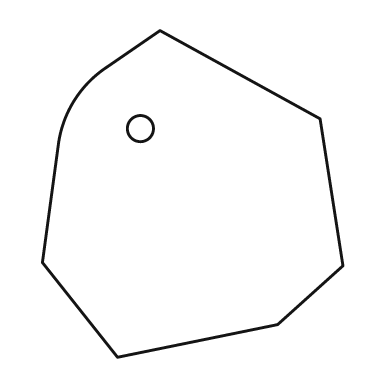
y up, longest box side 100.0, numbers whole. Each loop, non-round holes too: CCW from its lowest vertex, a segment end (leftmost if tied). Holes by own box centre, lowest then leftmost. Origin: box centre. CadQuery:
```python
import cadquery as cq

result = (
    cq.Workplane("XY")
    .moveTo(-23.0, -50.0)
    .lineTo(26.0, -40.0)
    .lineTo(46.0, -22.0)
    .lineTo(39.0, 23.0)
    .lineTo(-10.0, 50.0)
    .lineTo(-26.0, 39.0)
    .threePointArc((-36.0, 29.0), (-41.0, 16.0))
    .lineTo(-46.0, -21.0)
    .close()
    .moveTo(-16.0, 20.0)
    .circle(4.0)
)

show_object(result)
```